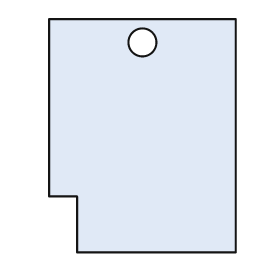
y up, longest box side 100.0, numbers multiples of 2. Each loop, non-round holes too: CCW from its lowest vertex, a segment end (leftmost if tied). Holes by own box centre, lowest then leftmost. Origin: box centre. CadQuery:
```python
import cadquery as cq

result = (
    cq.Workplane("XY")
    .moveTo(-28.0, -50.0)
    .lineTo(40.0, -50.0)
    .lineTo(40.0, 50.0)
    .lineTo(-40.0, 50.0)
    .lineTo(-40.0, -26.0)
    .lineTo(-28.0, -26.0)
    .close()
    .moveTo(0.0, 40.0)
    .circle(6.0)
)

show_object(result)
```